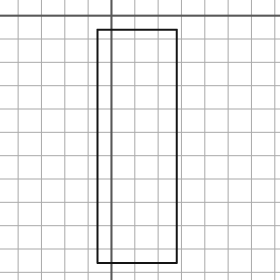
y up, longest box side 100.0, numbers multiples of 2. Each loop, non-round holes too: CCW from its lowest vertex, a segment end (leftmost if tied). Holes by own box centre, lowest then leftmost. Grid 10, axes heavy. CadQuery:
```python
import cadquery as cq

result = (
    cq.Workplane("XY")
    .moveTo(-6.0, -106.0)
    .lineTo(28.0, -106.0)
    .lineTo(28.0, -6.0)
    .lineTo(-6.0, -6.0)
    .close()
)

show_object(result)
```